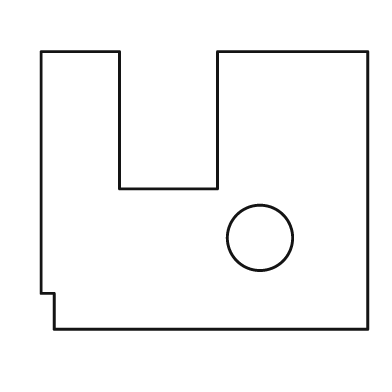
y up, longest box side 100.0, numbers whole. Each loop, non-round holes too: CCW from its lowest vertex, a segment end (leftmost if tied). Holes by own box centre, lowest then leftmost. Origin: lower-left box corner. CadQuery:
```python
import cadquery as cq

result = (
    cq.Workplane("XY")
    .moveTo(4.0, 0.0)
    .lineTo(100.0, 0.0)
    .lineTo(100.0, 85.0)
    .lineTo(54.0, 85.0)
    .lineTo(54.0, 43.0)
    .lineTo(24.0, 43.0)
    .lineTo(24.0, 85.0)
    .lineTo(0.0, 85.0)
    .lineTo(0.0, 11.0)
    .lineTo(4.0, 11.0)
    .close()
    .moveTo(67.0, 28.0)
    .circle(10.0)
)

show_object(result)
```